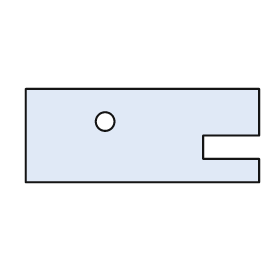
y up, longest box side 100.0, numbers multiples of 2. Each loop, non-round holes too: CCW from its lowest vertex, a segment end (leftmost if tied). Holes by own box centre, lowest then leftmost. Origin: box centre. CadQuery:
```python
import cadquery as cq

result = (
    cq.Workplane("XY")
    .moveTo(-50.0, -20.0)
    .lineTo(50.0, -20.0)
    .lineTo(50.0, -10.0)
    .lineTo(26.0, -10.0)
    .lineTo(26.0, 0.0)
    .lineTo(50.0, 0.0)
    .lineTo(50.0, 20.0)
    .lineTo(-50.0, 20.0)
    .close()
    .moveTo(-16.0, 6.0)
    .circle(4.0)
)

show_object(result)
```